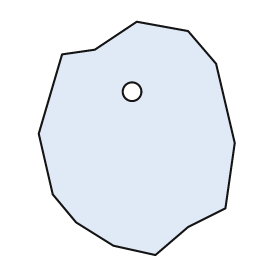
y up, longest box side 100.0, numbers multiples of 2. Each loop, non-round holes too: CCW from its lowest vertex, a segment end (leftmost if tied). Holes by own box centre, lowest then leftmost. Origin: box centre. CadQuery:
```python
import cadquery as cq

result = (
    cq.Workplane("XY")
    .moveTo(8.0, -50.0)
    .lineTo(22.0, -38.0)
    .lineTo(38.0, -30.0)
    .lineTo(42.0, -2.0)
    .lineTo(34.0, 32.0)
    .lineTo(22.0, 46.0)
    .lineTo(0.0, 50.0)
    .lineTo(-18.0, 38.0)
    .lineTo(-32.0, 36.0)
    .lineTo(-42.0, 2.0)
    .lineTo(-36.0, -24.0)
    .lineTo(-26.0, -36.0)
    .lineTo(-10.0, -46.0)
    .close()
    .moveTo(-2.0, 20.0)
    .circle(4.0)
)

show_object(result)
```